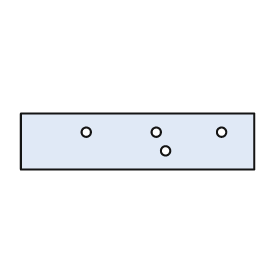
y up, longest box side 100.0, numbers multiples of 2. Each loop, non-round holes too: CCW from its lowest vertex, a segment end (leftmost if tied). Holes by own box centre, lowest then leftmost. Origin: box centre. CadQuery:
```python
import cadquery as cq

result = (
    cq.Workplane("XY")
    .moveTo(-50.0, -12.0)
    .lineTo(50.0, -12.0)
    .lineTo(50.0, 12.0)
    .lineTo(-50.0, 12.0)
    .close()
    .moveTo(12.0, -4.0)
    .circle(2.0)
    .moveTo(-22.0, 4.0)
    .circle(2.0)
    .moveTo(8.0, 4.0)
    .circle(2.0)
    .moveTo(36.0, 4.0)
    .circle(2.0)
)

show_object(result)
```